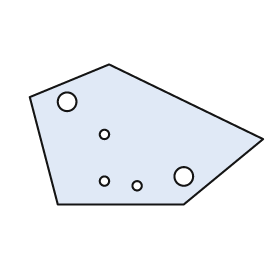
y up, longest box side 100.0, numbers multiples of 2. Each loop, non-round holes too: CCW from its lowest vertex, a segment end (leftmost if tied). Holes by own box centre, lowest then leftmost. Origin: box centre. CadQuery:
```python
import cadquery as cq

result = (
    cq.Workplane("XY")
    .moveTo(-38.0, -30.0)
    .lineTo(16.0, -30.0)
    .lineTo(50.0, -2.0)
    .lineTo(-16.0, 30.0)
    .lineTo(-50.0, 16.0)
    .close()
    .moveTo(-4.0, -22.0)
    .circle(2.0)
    .moveTo(-18.0, -20.0)
    .circle(2.0)
    .moveTo(16.0, -18.0)
    .circle(4.0)
    .moveTo(-18.0, 0.0)
    .circle(2.0)
    .moveTo(-34.0, 14.0)
    .circle(4.0)
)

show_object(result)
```